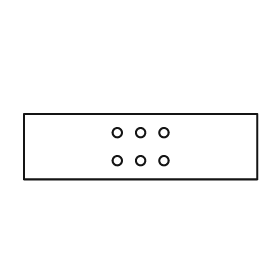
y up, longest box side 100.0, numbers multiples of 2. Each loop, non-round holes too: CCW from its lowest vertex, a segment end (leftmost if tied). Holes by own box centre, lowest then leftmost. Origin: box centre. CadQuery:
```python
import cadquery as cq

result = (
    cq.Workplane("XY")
    .moveTo(-50.0, -14.0)
    .lineTo(50.0, -14.0)
    .lineTo(50.0, 14.0)
    .lineTo(-50.0, 14.0)
    .close()
    .moveTo(-10.0, -6.0)
    .circle(2.0)
    .moveTo(0.0, -6.0)
    .circle(2.0)
    .moveTo(10.0, -6.0)
    .circle(2.0)
    .moveTo(-10.0, 6.0)
    .circle(2.0)
    .moveTo(0.0, 6.0)
    .circle(2.0)
    .moveTo(10.0, 6.0)
    .circle(2.0)
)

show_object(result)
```